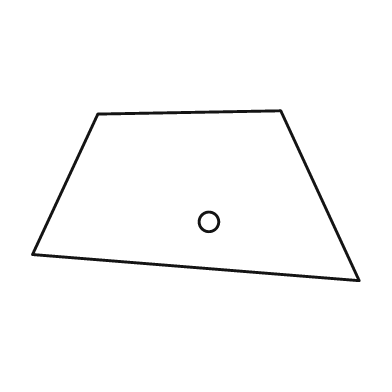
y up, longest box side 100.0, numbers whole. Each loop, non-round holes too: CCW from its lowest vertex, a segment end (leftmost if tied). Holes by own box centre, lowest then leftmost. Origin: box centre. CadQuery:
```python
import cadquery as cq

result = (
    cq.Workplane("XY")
    .moveTo(50.0, -26.0)
    .lineTo(26.0, 26.0)
    .lineTo(-30.0, 25.0)
    .lineTo(-50.0, -18.0)
    .close()
    .moveTo(4.0, -8.0)
    .circle(3.0)
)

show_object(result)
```